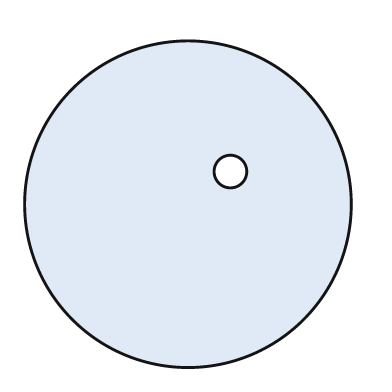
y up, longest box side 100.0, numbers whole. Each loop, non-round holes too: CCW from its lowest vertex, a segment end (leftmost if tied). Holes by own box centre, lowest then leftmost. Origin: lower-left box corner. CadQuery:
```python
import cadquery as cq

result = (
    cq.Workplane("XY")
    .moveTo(50.0, 50.0)
    .circle(50.0)
    .moveTo(63.0, 60.0)
    .circle(5.0)
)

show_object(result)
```